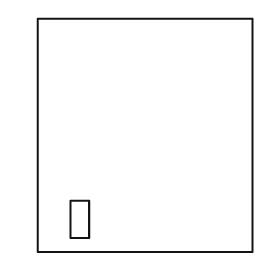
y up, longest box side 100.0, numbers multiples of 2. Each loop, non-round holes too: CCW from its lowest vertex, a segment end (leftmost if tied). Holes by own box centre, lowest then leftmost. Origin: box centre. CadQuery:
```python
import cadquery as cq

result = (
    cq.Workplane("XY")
    .moveTo(-46.0, -50.0)
    .lineTo(46.0, -50.0)
    .lineTo(46.0, 50.0)
    .lineTo(-46.0, 50.0)
    .close()
    .moveTo(-32.0, -44.0)
    .lineTo(-24.0, -44.0)
    .lineTo(-24.0, -28.0)
    .lineTo(-32.0, -28.0)
    .close()
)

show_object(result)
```